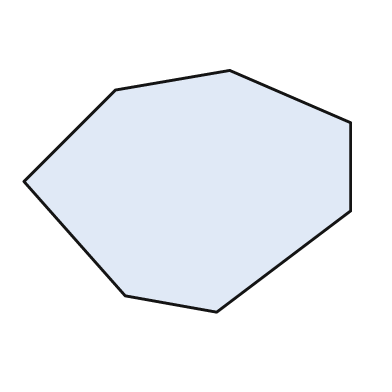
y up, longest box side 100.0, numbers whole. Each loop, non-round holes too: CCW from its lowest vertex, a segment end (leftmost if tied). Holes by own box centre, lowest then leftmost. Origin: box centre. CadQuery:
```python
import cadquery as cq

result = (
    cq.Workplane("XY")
    .moveTo(9.0, -37.0)
    .lineTo(50.0, -6.0)
    .lineTo(50.0, 21.0)
    .lineTo(13.0, 37.0)
    .lineTo(-22.0, 31.0)
    .lineTo(-50.0, 3.0)
    .lineTo(-19.0, -32.0)
    .close()
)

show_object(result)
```